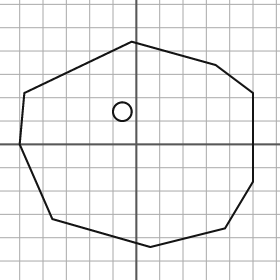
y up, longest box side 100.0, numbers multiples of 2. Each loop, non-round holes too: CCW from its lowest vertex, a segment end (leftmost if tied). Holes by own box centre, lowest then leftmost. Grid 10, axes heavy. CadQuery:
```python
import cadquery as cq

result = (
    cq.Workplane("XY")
    .moveTo(6.0, -44.0)
    .lineTo(38.0, -36.0)
    .lineTo(50.0, -16.0)
    .lineTo(50.0, 22.0)
    .lineTo(34.0, 34.0)
    .lineTo(-2.0, 44.0)
    .lineTo(-48.0, 22.0)
    .lineTo(-50.0, 0.0)
    .lineTo(-36.0, -32.0)
    .close()
    .moveTo(-6.0, 14.0)
    .circle(4.0)
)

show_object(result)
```